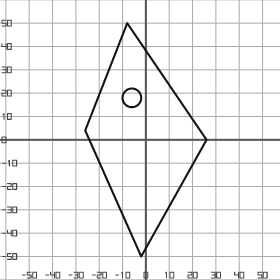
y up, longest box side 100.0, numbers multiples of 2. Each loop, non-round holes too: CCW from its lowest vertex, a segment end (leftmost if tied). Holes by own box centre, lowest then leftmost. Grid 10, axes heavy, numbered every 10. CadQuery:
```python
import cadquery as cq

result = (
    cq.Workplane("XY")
    .moveTo(-2.0, -50.0)
    .lineTo(26.0, 0.0)
    .lineTo(-8.0, 50.0)
    .lineTo(-26.0, 4.0)
    .close()
    .moveTo(-6.0, 18.0)
    .circle(4.0)
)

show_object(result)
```